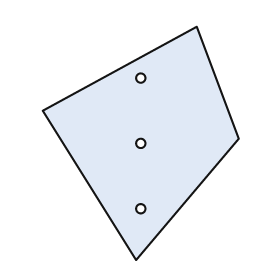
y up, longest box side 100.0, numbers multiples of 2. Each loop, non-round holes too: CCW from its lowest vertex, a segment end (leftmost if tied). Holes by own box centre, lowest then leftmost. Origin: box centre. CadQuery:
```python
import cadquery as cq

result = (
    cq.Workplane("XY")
    .moveTo(-2.0, -50.0)
    .lineTo(42.0, 2.0)
    .lineTo(24.0, 50.0)
    .lineTo(-42.0, 14.0)
    .close()
    .moveTo(0.0, -28.0)
    .circle(2.0)
    .moveTo(0.0, 0.0)
    .circle(2.0)
    .moveTo(0.0, 28.0)
    .circle(2.0)
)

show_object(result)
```